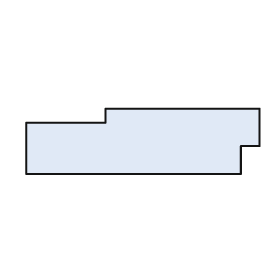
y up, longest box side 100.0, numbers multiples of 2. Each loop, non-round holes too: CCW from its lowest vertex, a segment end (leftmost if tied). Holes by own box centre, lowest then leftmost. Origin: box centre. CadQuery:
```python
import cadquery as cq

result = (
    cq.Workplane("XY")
    .moveTo(-50.0, -14.0)
    .lineTo(42.0, -14.0)
    .lineTo(42.0, -2.0)
    .lineTo(50.0, -2.0)
    .lineTo(50.0, 14.0)
    .lineTo(-16.0, 14.0)
    .lineTo(-16.0, 8.0)
    .lineTo(-50.0, 8.0)
    .close()
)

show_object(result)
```